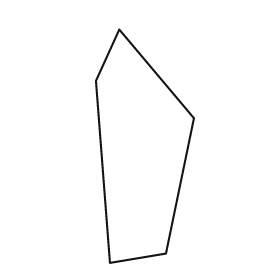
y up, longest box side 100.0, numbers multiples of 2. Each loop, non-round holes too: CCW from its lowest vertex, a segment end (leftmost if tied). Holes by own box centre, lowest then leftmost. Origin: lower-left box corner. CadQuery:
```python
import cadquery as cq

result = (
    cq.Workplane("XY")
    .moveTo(6.0, 0.0)
    .lineTo(30.0, 4.0)
    .lineTo(42.0, 62.0)
    .lineTo(10.0, 100.0)
    .lineTo(0.0, 78.0)
    .close()
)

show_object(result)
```